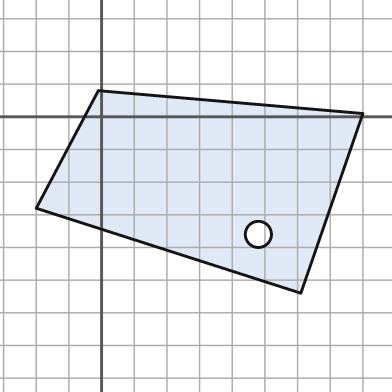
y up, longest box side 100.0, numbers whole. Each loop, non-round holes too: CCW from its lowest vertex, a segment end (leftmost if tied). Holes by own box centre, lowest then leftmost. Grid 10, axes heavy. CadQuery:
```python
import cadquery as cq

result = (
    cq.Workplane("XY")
    .moveTo(61.0, -54.0)
    .lineTo(80.0, 1.0)
    .lineTo(-1.0, 8.0)
    .lineTo(-20.0, -28.0)
    .close()
    .moveTo(48.0, -36.0)
    .circle(4.0)
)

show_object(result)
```